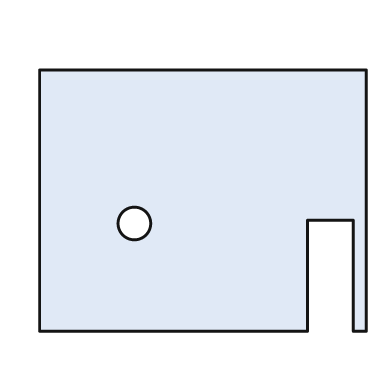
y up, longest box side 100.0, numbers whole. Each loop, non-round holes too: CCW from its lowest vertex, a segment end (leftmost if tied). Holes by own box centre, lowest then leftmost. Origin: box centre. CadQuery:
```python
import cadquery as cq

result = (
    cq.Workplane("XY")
    .moveTo(-50.0, -40.0)
    .lineTo(32.0, -40.0)
    .lineTo(32.0, -6.0)
    .lineTo(46.0, -6.0)
    .lineTo(46.0, -40.0)
    .lineTo(50.0, -40.0)
    .lineTo(50.0, 40.0)
    .lineTo(-50.0, 40.0)
    .close()
    .moveTo(-21.0, -7.0)
    .circle(5.0)
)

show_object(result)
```